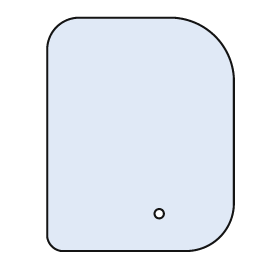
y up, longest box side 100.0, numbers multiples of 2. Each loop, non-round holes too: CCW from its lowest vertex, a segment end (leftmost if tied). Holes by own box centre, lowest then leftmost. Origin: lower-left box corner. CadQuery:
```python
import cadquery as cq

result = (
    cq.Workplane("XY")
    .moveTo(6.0, 0.0)
    .lineTo(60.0, 0.0)
    .threePointArc((74.0, 6.0), (80.0, 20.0))
    .lineTo(80.0, 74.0)
    .threePointArc((72.0, 92.0), (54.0, 100.0))
    .lineTo(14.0, 100.0)
    .threePointArc((4.0, 96.0), (0.0, 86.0))
    .lineTo(0.0, 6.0)
    .threePointArc((2.0, 2.0), (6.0, 0.0))
    .close()
    .moveTo(48.0, 16.0)
    .circle(2.0)
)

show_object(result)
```